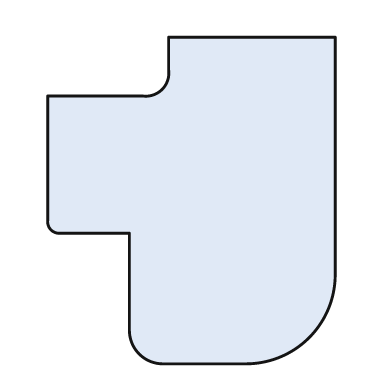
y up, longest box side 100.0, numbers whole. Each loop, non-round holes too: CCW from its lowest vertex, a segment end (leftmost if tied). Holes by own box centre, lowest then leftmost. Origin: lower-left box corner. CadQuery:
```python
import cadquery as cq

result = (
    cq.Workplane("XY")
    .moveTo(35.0, 0.0)
    .lineTo(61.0, 0.0)
    .threePointArc((80.0, 8.0), (88.0, 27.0))
    .lineTo(88.0, 100.0)
    .lineTo(37.0, 100.0)
    .lineTo(37.0, 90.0)
    .threePointArc((35.0, 84.0), (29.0, 82.0))
    .lineTo(0.0, 82.0)
    .lineTo(0.0, 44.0)
    .threePointArc((1.0, 41.0), (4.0, 40.0))
    .lineTo(25.0, 40.0)
    .lineTo(25.0, 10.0)
    .threePointArc((28.0, 3.0), (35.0, 0.0))
    .close()
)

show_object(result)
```